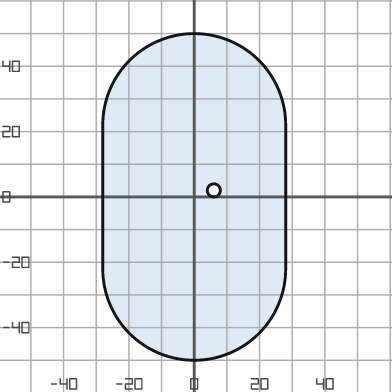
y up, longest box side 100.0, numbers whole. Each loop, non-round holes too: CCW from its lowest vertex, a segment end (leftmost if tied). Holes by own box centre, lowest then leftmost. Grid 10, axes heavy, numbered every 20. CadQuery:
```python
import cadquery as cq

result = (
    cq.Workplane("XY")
    .moveTo(-28.0, -22.0)
    .threePointArc((0.0, -50.0), (28.0, -22.0))
    .lineTo(28.0, 22.0)
    .threePointArc((0.0, 50.0), (-28.0, 22.0))
    .close()
    .moveTo(6.0, 2.0)
    .circle(2.0)
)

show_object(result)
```